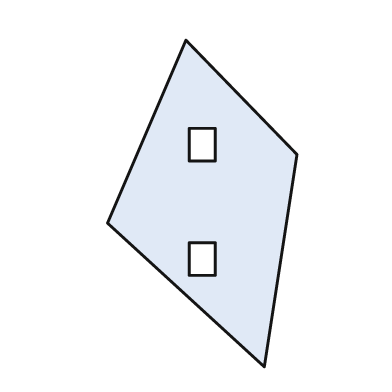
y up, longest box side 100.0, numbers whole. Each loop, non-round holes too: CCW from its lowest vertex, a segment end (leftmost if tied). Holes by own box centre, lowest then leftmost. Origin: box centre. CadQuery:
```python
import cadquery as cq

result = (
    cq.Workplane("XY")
    .moveTo(19.0, -50.0)
    .lineTo(29.0, 15.0)
    .lineTo(-5.0, 50.0)
    .lineTo(-29.0, -6.0)
    .close()
    .moveTo(-4.0, -22.0)
    .lineTo(4.0, -22.0)
    .lineTo(4.0, -12.0)
    .lineTo(-4.0, -12.0)
    .close()
    .moveTo(-4.0, 13.0)
    .lineTo(4.0, 13.0)
    .lineTo(4.0, 23.0)
    .lineTo(-4.0, 23.0)
    .close()
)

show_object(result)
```